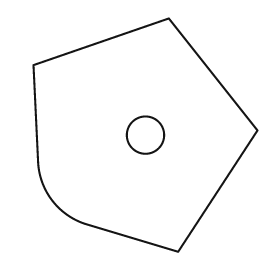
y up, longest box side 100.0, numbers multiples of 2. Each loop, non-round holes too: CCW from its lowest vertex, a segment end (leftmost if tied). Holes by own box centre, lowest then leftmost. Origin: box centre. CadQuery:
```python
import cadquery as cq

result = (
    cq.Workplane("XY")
    .moveTo(14.0, -50.0)
    .lineTo(48.0, 2.0)
    .lineTo(10.0, 50.0)
    .lineTo(-48.0, 30.0)
    .lineTo(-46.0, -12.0)
    .threePointArc((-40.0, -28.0), (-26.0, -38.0))
    .close()
    .moveTo(0.0, 0.0)
    .circle(8.0)
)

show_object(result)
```